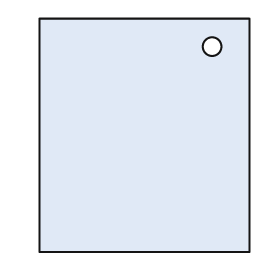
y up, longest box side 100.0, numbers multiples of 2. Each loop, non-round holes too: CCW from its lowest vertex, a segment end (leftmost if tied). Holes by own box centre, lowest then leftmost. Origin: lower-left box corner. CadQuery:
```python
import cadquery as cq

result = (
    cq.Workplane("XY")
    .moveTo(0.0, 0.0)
    .lineTo(90.0, 0.0)
    .lineTo(90.0, 100.0)
    .lineTo(0.0, 100.0)
    .close()
    .moveTo(74.0, 88.0)
    .circle(4.0)
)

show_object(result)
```